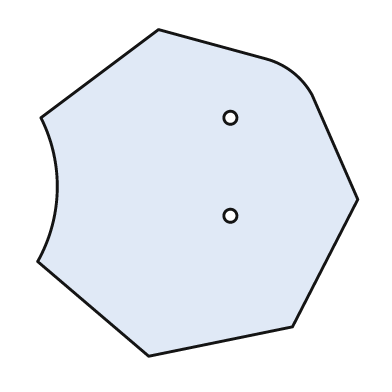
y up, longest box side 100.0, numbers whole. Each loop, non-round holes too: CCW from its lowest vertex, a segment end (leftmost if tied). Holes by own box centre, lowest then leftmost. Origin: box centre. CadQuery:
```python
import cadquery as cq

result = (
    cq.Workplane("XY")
    .moveTo(-15.0, -50.0)
    .lineTo(29.0, -41.0)
    .lineTo(49.0, -2.0)
    .lineTo(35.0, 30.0)
    .threePointArc((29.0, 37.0), (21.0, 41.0))
    .lineTo(-12.0, 50.0)
    .lineTo(-48.0, 23.0)
    .threePointArc((-43.0, 1.0), (-49.0, -21.0))
    .close()
    .moveTo(10.0, -7.0)
    .circle(2.0)
    .moveTo(10.0, 23.0)
    .circle(2.0)
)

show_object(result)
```